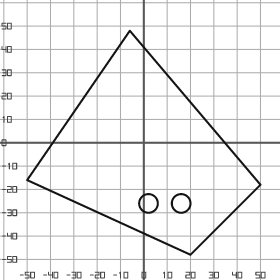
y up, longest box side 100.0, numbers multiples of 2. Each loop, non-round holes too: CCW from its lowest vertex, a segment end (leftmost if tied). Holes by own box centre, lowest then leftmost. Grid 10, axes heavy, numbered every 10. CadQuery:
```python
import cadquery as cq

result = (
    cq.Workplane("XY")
    .moveTo(20.0, -48.0)
    .lineTo(50.0, -18.0)
    .lineTo(-6.0, 48.0)
    .lineTo(-50.0, -16.0)
    .close()
    .moveTo(2.0, -26.0)
    .circle(4.0)
    .moveTo(16.0, -26.0)
    .circle(4.0)
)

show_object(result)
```